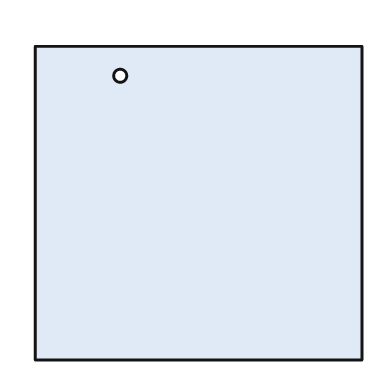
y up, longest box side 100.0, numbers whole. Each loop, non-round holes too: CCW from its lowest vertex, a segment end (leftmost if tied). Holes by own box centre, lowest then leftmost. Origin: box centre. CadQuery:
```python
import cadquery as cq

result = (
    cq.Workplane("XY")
    .moveTo(-50.0, -48.0)
    .lineTo(50.0, -48.0)
    .lineTo(50.0, 48.0)
    .lineTo(-50.0, 48.0)
    .close()
    .moveTo(-24.0, 39.0)
    .circle(2.0)
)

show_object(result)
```